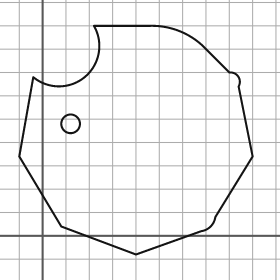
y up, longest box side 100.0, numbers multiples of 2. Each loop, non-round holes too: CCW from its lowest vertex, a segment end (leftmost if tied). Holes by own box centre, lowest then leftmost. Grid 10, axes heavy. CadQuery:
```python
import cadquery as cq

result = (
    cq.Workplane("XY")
    .moveTo(40.0, -8.0)
    .lineTo(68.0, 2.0)
    .threePointArc((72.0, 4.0), (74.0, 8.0))
    .lineTo(90.0, 34.0)
    .lineTo(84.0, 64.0)
    .threePointArc((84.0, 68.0), (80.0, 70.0))
    .lineTo(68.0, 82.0)
    .threePointArc((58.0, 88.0), (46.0, 90.0))
    .lineTo(22.0, 90.0)
    .threePointArc((18.0, 68.0), (-4.0, 68.0))
    .lineTo(-10.0, 34.0)
    .lineTo(8.0, 4.0)
    .close()
    .moveTo(12.0, 48.0)
    .circle(4.0)
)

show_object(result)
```